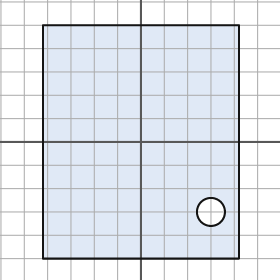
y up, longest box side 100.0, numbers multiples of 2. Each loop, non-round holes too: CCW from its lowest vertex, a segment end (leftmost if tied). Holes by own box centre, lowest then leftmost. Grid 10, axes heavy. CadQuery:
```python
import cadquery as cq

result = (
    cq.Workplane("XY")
    .moveTo(-42.0, -50.0)
    .lineTo(42.0, -50.0)
    .lineTo(42.0, 50.0)
    .lineTo(-42.0, 50.0)
    .close()
    .moveTo(30.0, -30.0)
    .circle(6.0)
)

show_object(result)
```